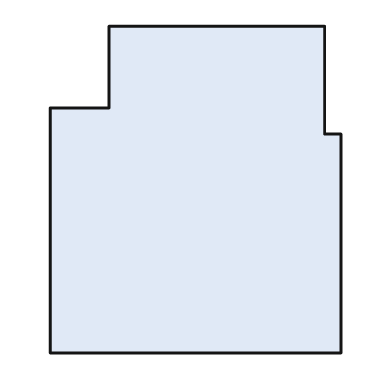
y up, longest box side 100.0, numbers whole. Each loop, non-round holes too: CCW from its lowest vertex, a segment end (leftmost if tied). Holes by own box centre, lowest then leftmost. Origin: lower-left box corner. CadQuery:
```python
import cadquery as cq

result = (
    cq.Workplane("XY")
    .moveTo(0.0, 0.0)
    .lineTo(89.0, 0.0)
    .lineTo(89.0, 67.0)
    .lineTo(84.0, 67.0)
    .lineTo(84.0, 100.0)
    .lineTo(18.0, 100.0)
    .lineTo(18.0, 75.0)
    .lineTo(0.0, 75.0)
    .close()
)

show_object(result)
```